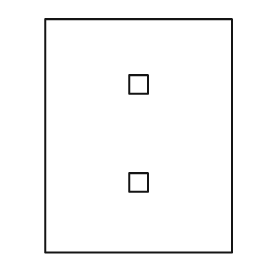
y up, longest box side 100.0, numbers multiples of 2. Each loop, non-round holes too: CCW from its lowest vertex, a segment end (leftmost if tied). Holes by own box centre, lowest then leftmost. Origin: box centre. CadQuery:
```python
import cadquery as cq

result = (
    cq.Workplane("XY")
    .moveTo(-40.0, -50.0)
    .lineTo(40.0, -50.0)
    .lineTo(40.0, 50.0)
    .lineTo(-40.0, 50.0)
    .close()
    .moveTo(-4.0, -24.0)
    .lineTo(4.0, -24.0)
    .lineTo(4.0, -16.0)
    .lineTo(-4.0, -16.0)
    .close()
    .moveTo(-4.0, 18.0)
    .lineTo(4.0, 18.0)
    .lineTo(4.0, 26.0)
    .lineTo(-4.0, 26.0)
    .close()
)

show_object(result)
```